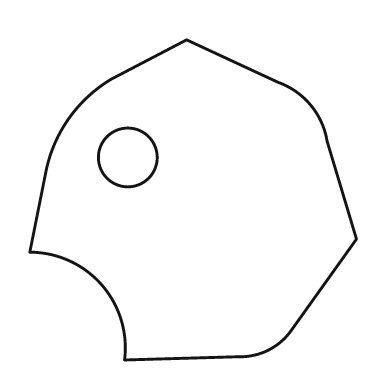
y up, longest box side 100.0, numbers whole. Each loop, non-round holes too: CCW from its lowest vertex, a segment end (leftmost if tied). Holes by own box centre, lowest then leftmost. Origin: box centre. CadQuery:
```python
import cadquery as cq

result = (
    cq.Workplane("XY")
    .moveTo(-21.0, -49.0)
    .lineTo(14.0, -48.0)
    .threePointArc((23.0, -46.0), (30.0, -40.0))
    .lineTo(50.0, -12.0)
    .lineTo(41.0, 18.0)
    .threePointArc((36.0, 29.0), (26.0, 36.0))
    .lineTo(-2.0, 49.0)
    .lineTo(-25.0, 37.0)
    .threePointArc((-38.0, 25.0), (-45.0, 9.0))
    .lineTo(-50.0, -16.0)
    .threePointArc((-28.0, -26.0), (-21.0, -49.0))
    .close()
    .moveTo(-20.0, 13.0)
    .circle(9.0)
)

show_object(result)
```